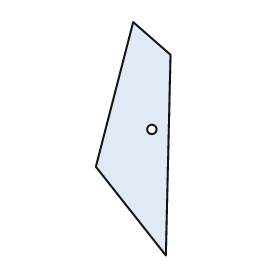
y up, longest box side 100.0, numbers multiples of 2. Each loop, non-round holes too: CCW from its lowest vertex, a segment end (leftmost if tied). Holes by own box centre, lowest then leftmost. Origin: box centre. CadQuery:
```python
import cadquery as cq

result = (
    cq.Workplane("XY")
    .moveTo(14.0, -50.0)
    .lineTo(16.0, 36.0)
    .lineTo(0.0, 50.0)
    .lineTo(-16.0, -12.0)
    .close()
    .moveTo(8.0, 4.0)
    .circle(2.0)
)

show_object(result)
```